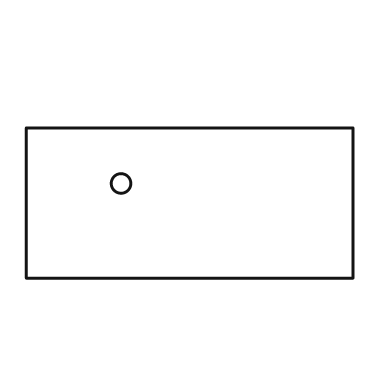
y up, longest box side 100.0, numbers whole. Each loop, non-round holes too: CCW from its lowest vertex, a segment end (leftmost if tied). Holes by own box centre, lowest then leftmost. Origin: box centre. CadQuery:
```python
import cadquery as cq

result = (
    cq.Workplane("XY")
    .moveTo(-50.0, -23.0)
    .lineTo(50.0, -23.0)
    .lineTo(50.0, 23.0)
    .lineTo(-50.0, 23.0)
    .close()
    .moveTo(-21.0, 6.0)
    .circle(3.0)
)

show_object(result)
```